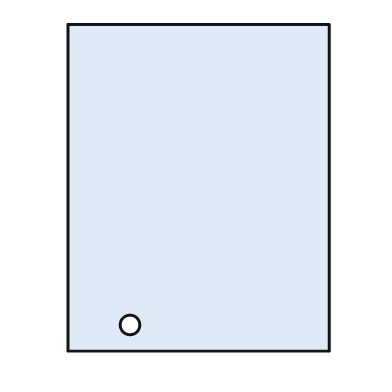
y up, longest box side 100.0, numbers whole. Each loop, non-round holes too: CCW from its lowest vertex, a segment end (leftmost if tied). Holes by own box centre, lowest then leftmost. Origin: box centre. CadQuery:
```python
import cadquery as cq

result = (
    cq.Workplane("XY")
    .moveTo(-40.0, -50.0)
    .lineTo(40.0, -50.0)
    .lineTo(40.0, 50.0)
    .lineTo(-40.0, 50.0)
    .close()
    .moveTo(-21.0, -42.0)
    .circle(3.0)
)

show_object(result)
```